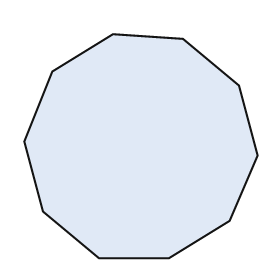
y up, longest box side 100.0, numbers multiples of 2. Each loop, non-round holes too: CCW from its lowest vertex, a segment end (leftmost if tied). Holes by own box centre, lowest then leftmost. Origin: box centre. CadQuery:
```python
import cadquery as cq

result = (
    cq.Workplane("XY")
    .moveTo(-18.0, -48.0)
    .lineTo(12.0, -48.0)
    .lineTo(38.0, -32.0)
    .lineTo(50.0, -4.0)
    .lineTo(42.0, 26.0)
    .lineTo(18.0, 46.0)
    .lineTo(-12.0, 48.0)
    .lineTo(-38.0, 32.0)
    .lineTo(-50.0, 2.0)
    .lineTo(-42.0, -28.0)
    .close()
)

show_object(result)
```